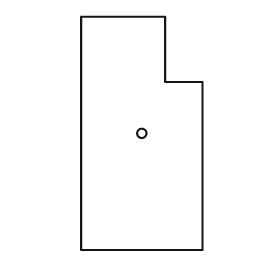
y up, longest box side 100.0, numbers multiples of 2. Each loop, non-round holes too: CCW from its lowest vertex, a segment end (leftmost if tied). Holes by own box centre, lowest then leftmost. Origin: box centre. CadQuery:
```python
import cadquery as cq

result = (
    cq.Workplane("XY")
    .moveTo(-26.0, -50.0)
    .lineTo(26.0, -50.0)
    .lineTo(26.0, 22.0)
    .lineTo(10.0, 22.0)
    .lineTo(10.0, 50.0)
    .lineTo(-26.0, 50.0)
    .close()
    .moveTo(0.0, 0.0)
    .circle(2.0)
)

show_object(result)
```